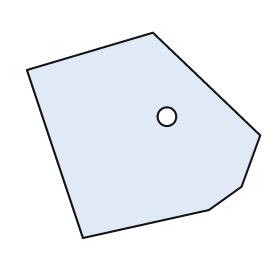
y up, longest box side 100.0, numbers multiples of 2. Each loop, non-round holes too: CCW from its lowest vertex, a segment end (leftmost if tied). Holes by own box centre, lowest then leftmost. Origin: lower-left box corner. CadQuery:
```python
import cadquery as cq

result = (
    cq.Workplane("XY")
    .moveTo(24.0, 0.0)
    .lineTo(78.0, 12.0)
    .lineTo(92.0, 22.0)
    .lineTo(100.0, 44.0)
    .lineTo(54.0, 88.0)
    .lineTo(0.0, 72.0)
    .close()
    .moveTo(60.0, 52.0)
    .circle(4.0)
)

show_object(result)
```